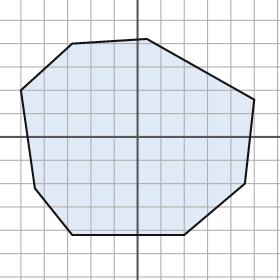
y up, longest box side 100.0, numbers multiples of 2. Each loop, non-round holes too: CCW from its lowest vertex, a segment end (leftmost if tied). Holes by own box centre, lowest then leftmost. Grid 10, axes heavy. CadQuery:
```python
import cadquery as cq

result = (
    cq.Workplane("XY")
    .moveTo(-28.0, -42.0)
    .lineTo(20.0, -42.0)
    .lineTo(46.0, -20.0)
    .lineTo(50.0, 16.0)
    .lineTo(4.0, 42.0)
    .lineTo(-28.0, 40.0)
    .lineTo(-50.0, 20.0)
    .lineTo(-44.0, -22.0)
    .close()
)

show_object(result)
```